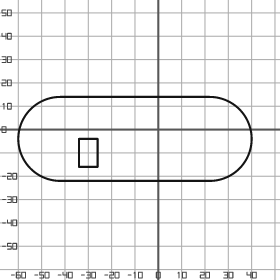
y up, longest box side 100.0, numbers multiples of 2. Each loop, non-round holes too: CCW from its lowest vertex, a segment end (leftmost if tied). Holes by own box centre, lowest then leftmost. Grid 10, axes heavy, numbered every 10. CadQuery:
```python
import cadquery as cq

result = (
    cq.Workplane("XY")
    .moveTo(-42.0, -22.0)
    .lineTo(22.0, -22.0)
    .threePointArc((40.0, -4.0), (22.0, 14.0))
    .lineTo(-42.0, 14.0)
    .threePointArc((-60.0, -4.0), (-42.0, -22.0))
    .close()
    .moveTo(-34.0, -16.0)
    .lineTo(-26.0, -16.0)
    .lineTo(-26.0, -4.0)
    .lineTo(-34.0, -4.0)
    .close()
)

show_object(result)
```